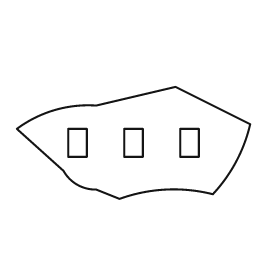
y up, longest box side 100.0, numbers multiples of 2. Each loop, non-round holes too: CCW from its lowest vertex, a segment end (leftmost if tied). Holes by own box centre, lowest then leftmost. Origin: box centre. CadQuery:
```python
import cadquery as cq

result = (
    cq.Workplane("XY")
    .moveTo(-6.0, -24.0)
    .threePointArc((14.0, -20.0), (34.0, -22.0))
    .threePointArc((44.0, -8.0), (50.0, 8.0))
    .lineTo(18.0, 24.0)
    .lineTo(-16.0, 16.0)
    .threePointArc((-34.0, 14.0), (-50.0, 6.0))
    .lineTo(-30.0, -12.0)
    .threePointArc((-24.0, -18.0), (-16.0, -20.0))
    .close()
    .moveTo(-28.0, -6.0)
    .lineTo(-20.0, -6.0)
    .lineTo(-20.0, 6.0)
    .lineTo(-28.0, 6.0)
    .close()
    .moveTo(-4.0, -6.0)
    .lineTo(4.0, -6.0)
    .lineTo(4.0, 6.0)
    .lineTo(-4.0, 6.0)
    .close()
    .moveTo(20.0, -6.0)
    .lineTo(28.0, -6.0)
    .lineTo(28.0, 6.0)
    .lineTo(20.0, 6.0)
    .close()
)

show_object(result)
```